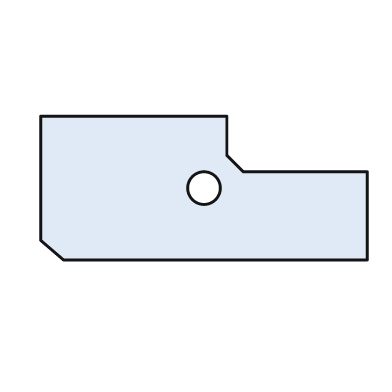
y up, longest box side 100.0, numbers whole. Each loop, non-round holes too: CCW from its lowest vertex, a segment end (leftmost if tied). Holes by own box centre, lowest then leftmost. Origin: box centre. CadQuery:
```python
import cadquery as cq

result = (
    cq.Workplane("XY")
    .moveTo(-43.0, -22.0)
    .lineTo(50.0, -22.0)
    .lineTo(50.0, 5.0)
    .lineTo(12.0, 5.0)
    .lineTo(7.0, 10.0)
    .lineTo(7.0, 22.0)
    .lineTo(-50.0, 22.0)
    .lineTo(-50.0, -16.0)
    .close()
    .moveTo(0.0, 0.0)
    .circle(5.0)
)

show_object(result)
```